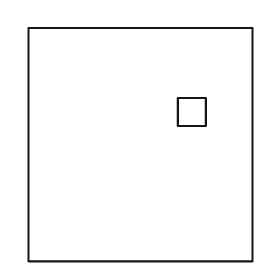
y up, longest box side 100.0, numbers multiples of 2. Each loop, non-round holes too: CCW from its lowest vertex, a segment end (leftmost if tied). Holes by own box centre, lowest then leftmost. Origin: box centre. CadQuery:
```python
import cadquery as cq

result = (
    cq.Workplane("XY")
    .moveTo(-48.0, -50.0)
    .lineTo(48.0, -50.0)
    .lineTo(48.0, 50.0)
    .lineTo(-48.0, 50.0)
    .close()
    .moveTo(16.0, 8.0)
    .lineTo(28.0, 8.0)
    .lineTo(28.0, 20.0)
    .lineTo(16.0, 20.0)
    .close()
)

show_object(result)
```